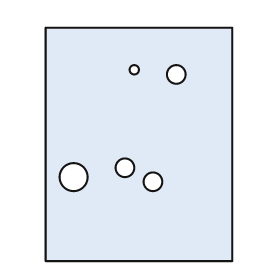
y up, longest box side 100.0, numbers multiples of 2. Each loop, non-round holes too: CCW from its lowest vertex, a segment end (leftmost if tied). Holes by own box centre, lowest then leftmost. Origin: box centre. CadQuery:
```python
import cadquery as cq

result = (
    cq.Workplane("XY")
    .moveTo(-40.0, -50.0)
    .lineTo(40.0, -50.0)
    .lineTo(40.0, 50.0)
    .lineTo(-40.0, 50.0)
    .close()
    .moveTo(6.0, -16.0)
    .circle(4.0)
    .moveTo(-28.0, -14.0)
    .circle(6.0)
    .moveTo(-6.0, -10.0)
    .circle(4.0)
    .moveTo(16.0, 30.0)
    .circle(4.0)
    .moveTo(-2.0, 32.0)
    .circle(2.0)
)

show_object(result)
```